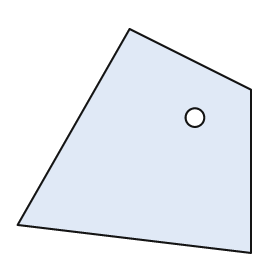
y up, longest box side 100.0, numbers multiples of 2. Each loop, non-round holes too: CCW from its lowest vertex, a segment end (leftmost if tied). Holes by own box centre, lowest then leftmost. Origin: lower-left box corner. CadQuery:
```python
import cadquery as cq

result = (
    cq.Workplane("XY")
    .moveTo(100.0, 0.0)
    .lineTo(100.0, 70.0)
    .lineTo(48.0, 96.0)
    .lineTo(0.0, 12.0)
    .close()
    .moveTo(76.0, 58.0)
    .circle(4.0)
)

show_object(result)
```